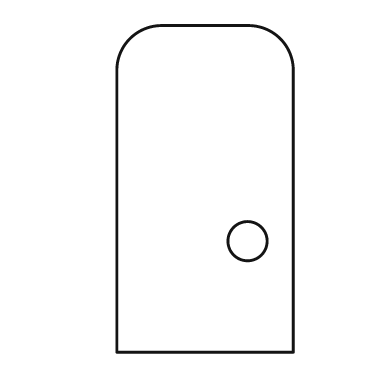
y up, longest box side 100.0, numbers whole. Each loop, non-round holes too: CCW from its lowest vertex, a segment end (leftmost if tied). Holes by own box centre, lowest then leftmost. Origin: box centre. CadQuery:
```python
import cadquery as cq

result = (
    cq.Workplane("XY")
    .moveTo(-27.0, -50.0)
    .lineTo(27.0, -50.0)
    .lineTo(27.0, 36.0)
    .threePointArc((23.0, 46.0), (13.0, 50.0))
    .lineTo(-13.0, 50.0)
    .threePointArc((-23.0, 46.0), (-27.0, 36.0))
    .close()
    .moveTo(13.0, -16.0)
    .circle(6.0)
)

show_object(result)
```